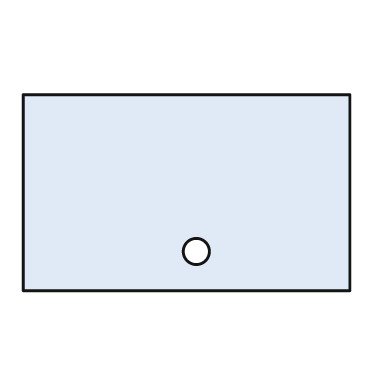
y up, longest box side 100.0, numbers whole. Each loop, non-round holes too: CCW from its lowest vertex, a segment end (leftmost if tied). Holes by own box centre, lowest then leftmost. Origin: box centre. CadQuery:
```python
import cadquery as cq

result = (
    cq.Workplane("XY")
    .moveTo(-50.0, -30.0)
    .lineTo(50.0, -30.0)
    .lineTo(50.0, 30.0)
    .lineTo(-50.0, 30.0)
    .close()
    .moveTo(3.0, -18.0)
    .circle(4.0)
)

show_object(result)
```